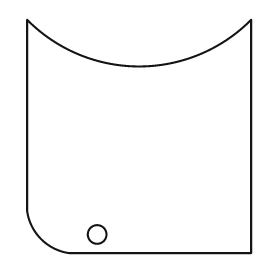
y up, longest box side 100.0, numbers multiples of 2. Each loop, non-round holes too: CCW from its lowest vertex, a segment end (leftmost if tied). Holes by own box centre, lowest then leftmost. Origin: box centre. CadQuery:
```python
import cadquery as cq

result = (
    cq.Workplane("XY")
    .moveTo(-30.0, -50.0)
    .lineTo(48.0, -50.0)
    .lineTo(48.0, 50.0)
    .threePointArc((0.0, 30.0), (-48.0, 50.0))
    .lineTo(-48.0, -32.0)
    .threePointArc((-42.0, -44.0), (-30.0, -50.0))
    .close()
    .moveTo(-18.0, -42.0)
    .circle(4.0)
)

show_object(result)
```